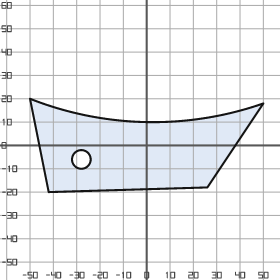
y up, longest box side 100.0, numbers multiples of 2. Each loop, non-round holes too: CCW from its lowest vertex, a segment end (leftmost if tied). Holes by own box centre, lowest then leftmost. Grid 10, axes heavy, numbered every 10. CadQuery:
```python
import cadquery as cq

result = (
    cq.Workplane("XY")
    .moveTo(-42.0, -20.0)
    .lineTo(26.0, -18.0)
    .lineTo(50.0, 18.0)
    .threePointArc((0.0, 10.0), (-50.0, 20.0))
    .close()
    .moveTo(-28.0, -6.0)
    .circle(4.0)
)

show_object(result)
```